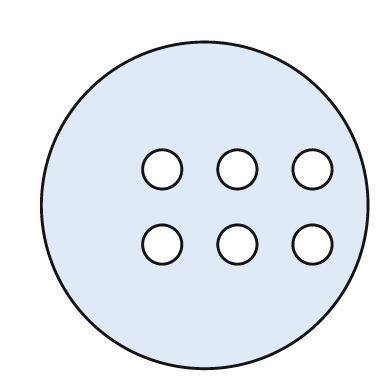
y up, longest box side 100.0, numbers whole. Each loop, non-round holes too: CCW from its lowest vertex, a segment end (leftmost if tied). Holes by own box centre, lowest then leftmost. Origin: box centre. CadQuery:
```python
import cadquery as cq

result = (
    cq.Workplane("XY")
    .moveTo(0.0, 0.0)
    .circle(50.0)
    .moveTo(-13.0, -12.0)
    .circle(6.0)
    .moveTo(10.0, -12.0)
    .circle(6.0)
    .moveTo(33.0, -12.0)
    .circle(6.0)
    .moveTo(-13.0, 11.0)
    .circle(6.0)
    .moveTo(10.0, 11.0)
    .circle(6.0)
    .moveTo(33.0, 11.0)
    .circle(6.0)
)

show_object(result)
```